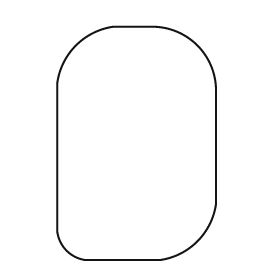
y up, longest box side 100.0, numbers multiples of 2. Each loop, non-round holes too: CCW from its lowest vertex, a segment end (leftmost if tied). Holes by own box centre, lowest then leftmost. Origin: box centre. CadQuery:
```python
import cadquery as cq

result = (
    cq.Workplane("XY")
    .moveTo(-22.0, -50.0)
    .lineTo(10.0, -50.0)
    .threePointArc((26.0, -42.0), (34.0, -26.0))
    .lineTo(34.0, 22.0)
    .threePointArc((26.0, 42.0), (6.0, 50.0))
    .lineTo(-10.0, 50.0)
    .threePointArc((-26.0, 42.0), (-34.0, 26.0))
    .lineTo(-34.0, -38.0)
    .threePointArc((-30.0, -46.0), (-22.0, -50.0))
    .close()
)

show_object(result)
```